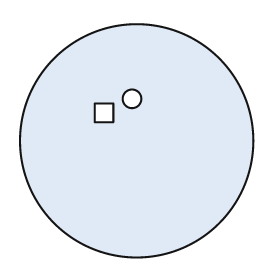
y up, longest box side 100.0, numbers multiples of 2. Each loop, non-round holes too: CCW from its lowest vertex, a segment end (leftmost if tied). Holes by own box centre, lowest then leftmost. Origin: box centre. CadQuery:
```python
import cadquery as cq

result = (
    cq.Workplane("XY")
    .moveTo(0.0, 0.0)
    .circle(50.0)
    .moveTo(-18.0, 8.0)
    .lineTo(-10.0, 8.0)
    .lineTo(-10.0, 16.0)
    .lineTo(-18.0, 16.0)
    .close()
    .moveTo(-2.0, 18.0)
    .circle(4.0)
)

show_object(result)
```